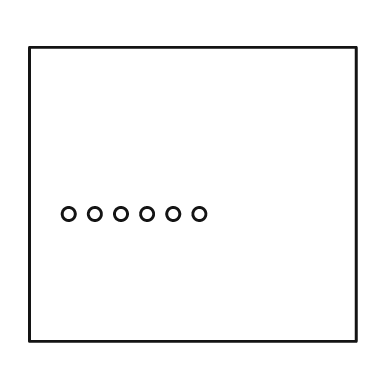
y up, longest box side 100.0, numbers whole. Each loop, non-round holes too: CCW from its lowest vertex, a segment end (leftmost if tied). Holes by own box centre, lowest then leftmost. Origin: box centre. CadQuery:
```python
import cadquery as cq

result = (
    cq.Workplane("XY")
    .moveTo(-50.0, -45.0)
    .lineTo(50.0, -45.0)
    .lineTo(50.0, 45.0)
    .lineTo(-50.0, 45.0)
    .close()
    .moveTo(-38.0, -6.0)
    .circle(2.0)
    .moveTo(-30.0, -6.0)
    .circle(2.0)
    .moveTo(-22.0, -6.0)
    .circle(2.0)
    .moveTo(-14.0, -6.0)
    .circle(2.0)
    .moveTo(-6.0, -6.0)
    .circle(2.0)
    .moveTo(2.0, -6.0)
    .circle(2.0)
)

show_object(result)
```